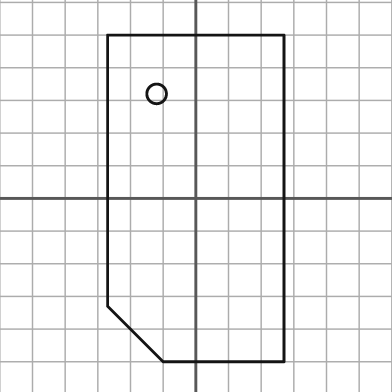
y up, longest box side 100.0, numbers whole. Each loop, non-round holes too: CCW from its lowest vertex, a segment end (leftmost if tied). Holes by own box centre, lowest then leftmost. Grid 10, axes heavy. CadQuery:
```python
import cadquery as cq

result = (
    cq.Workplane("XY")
    .moveTo(-10.0, -50.0)
    .lineTo(27.0, -50.0)
    .lineTo(27.0, 50.0)
    .lineTo(-27.0, 50.0)
    .lineTo(-27.0, -33.0)
    .close()
    .moveTo(-12.0, 32.0)
    .circle(3.0)
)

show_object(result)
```